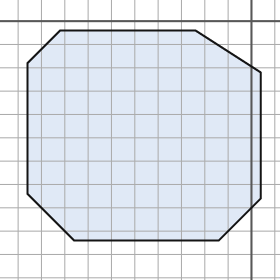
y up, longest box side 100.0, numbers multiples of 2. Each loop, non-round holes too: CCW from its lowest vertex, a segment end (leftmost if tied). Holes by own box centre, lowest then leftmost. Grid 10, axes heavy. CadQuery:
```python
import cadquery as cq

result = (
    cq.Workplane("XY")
    .moveTo(-76.0, -94.0)
    .lineTo(-14.0, -94.0)
    .lineTo(4.0, -76.0)
    .lineTo(4.0, -22.0)
    .lineTo(-24.0, -4.0)
    .lineTo(-82.0, -4.0)
    .lineTo(-96.0, -18.0)
    .lineTo(-96.0, -74.0)
    .close()
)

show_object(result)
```